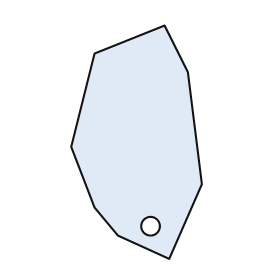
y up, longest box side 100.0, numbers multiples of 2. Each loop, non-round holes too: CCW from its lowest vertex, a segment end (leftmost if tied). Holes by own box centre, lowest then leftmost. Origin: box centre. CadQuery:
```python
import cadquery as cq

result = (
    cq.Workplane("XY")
    .moveTo(14.0, -50.0)
    .lineTo(28.0, -18.0)
    .lineTo(22.0, 30.0)
    .lineTo(12.0, 50.0)
    .lineTo(-18.0, 38.0)
    .lineTo(-28.0, -2.0)
    .lineTo(-18.0, -28.0)
    .lineTo(-8.0, -40.0)
    .close()
    .moveTo(6.0, -36.0)
    .circle(4.0)
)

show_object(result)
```